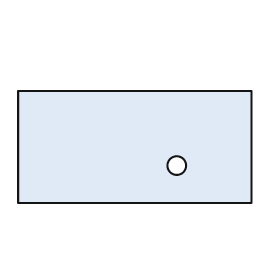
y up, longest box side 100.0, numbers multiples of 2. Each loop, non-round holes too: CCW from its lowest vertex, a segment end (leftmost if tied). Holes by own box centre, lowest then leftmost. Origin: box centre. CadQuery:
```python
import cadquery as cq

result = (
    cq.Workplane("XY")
    .moveTo(-50.0, -24.0)
    .lineTo(50.0, -24.0)
    .lineTo(50.0, 24.0)
    .lineTo(-50.0, 24.0)
    .close()
    .moveTo(18.0, -8.0)
    .circle(4.0)
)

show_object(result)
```